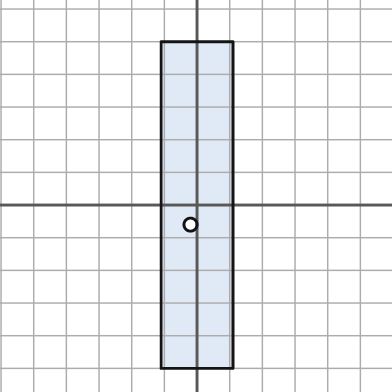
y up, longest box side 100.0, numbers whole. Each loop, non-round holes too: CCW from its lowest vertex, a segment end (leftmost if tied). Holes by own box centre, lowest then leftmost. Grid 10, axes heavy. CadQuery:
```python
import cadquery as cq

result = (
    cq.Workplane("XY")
    .moveTo(-11.0, -50.0)
    .lineTo(11.0, -50.0)
    .lineTo(11.0, 50.0)
    .lineTo(-11.0, 50.0)
    .close()
    .moveTo(-2.0, -6.0)
    .circle(2.0)
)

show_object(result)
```